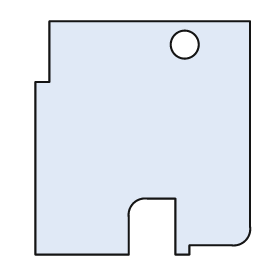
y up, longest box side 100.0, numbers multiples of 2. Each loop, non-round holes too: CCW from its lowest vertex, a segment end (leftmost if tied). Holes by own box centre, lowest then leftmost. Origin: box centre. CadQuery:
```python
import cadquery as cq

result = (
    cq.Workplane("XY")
    .moveTo(-46.0, -50.0)
    .lineTo(-6.0, -50.0)
    .lineTo(-6.0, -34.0)
    .threePointArc((-4.0, -28.0), (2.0, -26.0))
    .lineTo(14.0, -26.0)
    .lineTo(14.0, -50.0)
    .lineTo(20.0, -50.0)
    .lineTo(20.0, -46.0)
    .lineTo(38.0, -46.0)
    .threePointArc((44.0, -44.0), (46.0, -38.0))
    .lineTo(46.0, 50.0)
    .lineTo(-40.0, 50.0)
    .lineTo(-40.0, 24.0)
    .lineTo(-46.0, 24.0)
    .close()
    .moveTo(18.0, 40.0)
    .circle(6.0)
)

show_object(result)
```